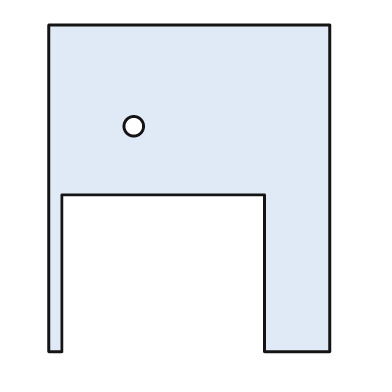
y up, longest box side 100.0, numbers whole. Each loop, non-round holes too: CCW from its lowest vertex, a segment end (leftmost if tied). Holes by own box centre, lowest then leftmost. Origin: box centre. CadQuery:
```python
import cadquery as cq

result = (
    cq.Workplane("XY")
    .moveTo(-43.0, -50.0)
    .lineTo(-39.0, -50.0)
    .lineTo(-39.0, -2.0)
    .lineTo(23.0, -2.0)
    .lineTo(23.0, -50.0)
    .lineTo(43.0, -50.0)
    .lineTo(43.0, 50.0)
    .lineTo(-43.0, 50.0)
    .close()
    .moveTo(-17.0, 19.0)
    .circle(3.0)
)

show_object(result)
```